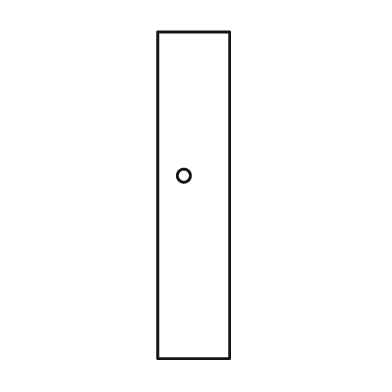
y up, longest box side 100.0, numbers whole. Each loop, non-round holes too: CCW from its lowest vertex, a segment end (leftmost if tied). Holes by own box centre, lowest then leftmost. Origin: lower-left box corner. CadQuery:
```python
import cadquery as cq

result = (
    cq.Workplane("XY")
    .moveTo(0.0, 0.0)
    .lineTo(22.0, 0.0)
    .lineTo(22.0, 100.0)
    .lineTo(0.0, 100.0)
    .close()
    .moveTo(8.0, 56.0)
    .circle(2.0)
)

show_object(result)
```